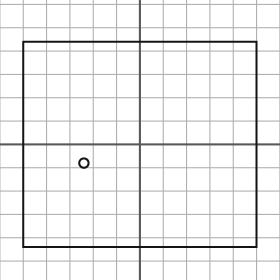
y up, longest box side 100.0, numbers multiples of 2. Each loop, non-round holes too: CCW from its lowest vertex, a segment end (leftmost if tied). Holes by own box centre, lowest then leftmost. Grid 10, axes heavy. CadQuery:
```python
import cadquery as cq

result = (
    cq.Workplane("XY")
    .moveTo(-50.0, -44.0)
    .lineTo(50.0, -44.0)
    .lineTo(50.0, 44.0)
    .lineTo(-50.0, 44.0)
    .close()
    .moveTo(-24.0, -8.0)
    .circle(2.0)
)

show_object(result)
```